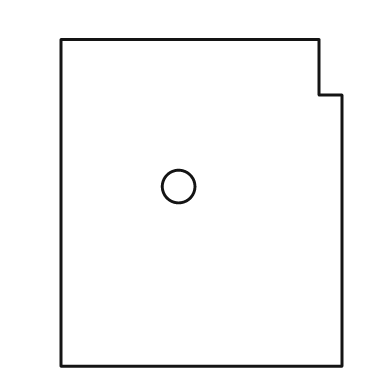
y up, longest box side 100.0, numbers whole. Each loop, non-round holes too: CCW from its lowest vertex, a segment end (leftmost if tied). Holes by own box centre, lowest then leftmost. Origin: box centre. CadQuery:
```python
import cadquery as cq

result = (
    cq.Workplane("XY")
    .moveTo(-43.0, -50.0)
    .lineTo(43.0, -50.0)
    .lineTo(43.0, 33.0)
    .lineTo(36.0, 33.0)
    .lineTo(36.0, 50.0)
    .lineTo(-43.0, 50.0)
    .close()
    .moveTo(-7.0, 5.0)
    .circle(5.0)
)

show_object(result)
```